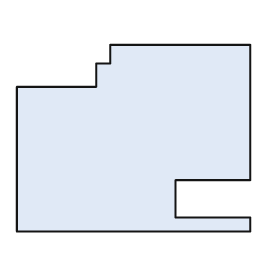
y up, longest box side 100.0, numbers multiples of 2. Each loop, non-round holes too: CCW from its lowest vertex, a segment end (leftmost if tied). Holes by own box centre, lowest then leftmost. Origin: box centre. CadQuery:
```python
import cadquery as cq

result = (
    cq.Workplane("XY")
    .moveTo(-50.0, -40.0)
    .lineTo(50.0, -40.0)
    .lineTo(50.0, -34.0)
    .lineTo(18.0, -34.0)
    .lineTo(18.0, -18.0)
    .lineTo(50.0, -18.0)
    .lineTo(50.0, 40.0)
    .lineTo(-10.0, 40.0)
    .lineTo(-10.0, 32.0)
    .lineTo(-16.0, 32.0)
    .lineTo(-16.0, 22.0)
    .lineTo(-50.0, 22.0)
    .close()
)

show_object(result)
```